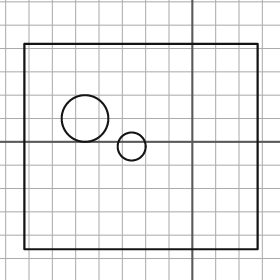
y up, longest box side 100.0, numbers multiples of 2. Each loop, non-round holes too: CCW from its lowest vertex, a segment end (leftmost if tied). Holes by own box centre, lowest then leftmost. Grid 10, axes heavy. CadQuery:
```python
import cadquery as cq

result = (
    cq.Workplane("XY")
    .moveTo(-72.0, -46.0)
    .lineTo(28.0, -46.0)
    .lineTo(28.0, 42.0)
    .lineTo(-72.0, 42.0)
    .close()
    .moveTo(-26.0, -2.0)
    .circle(6.0)
    .moveTo(-46.0, 10.0)
    .circle(10.0)
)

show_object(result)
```